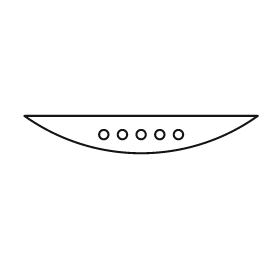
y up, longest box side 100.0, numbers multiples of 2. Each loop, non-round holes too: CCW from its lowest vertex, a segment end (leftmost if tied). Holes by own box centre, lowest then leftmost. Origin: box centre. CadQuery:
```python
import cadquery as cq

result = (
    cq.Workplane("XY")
    .moveTo(-50.0, 8.0)
    .threePointArc((0.0, -8.0), (50.0, 8.0))
    .close()
    .moveTo(-16.0, 0.0)
    .circle(2.0)
    .moveTo(-8.0, 0.0)
    .circle(2.0)
    .moveTo(0.0, 0.0)
    .circle(2.0)
    .moveTo(8.0, 0.0)
    .circle(2.0)
    .moveTo(16.0, 0.0)
    .circle(2.0)
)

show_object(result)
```